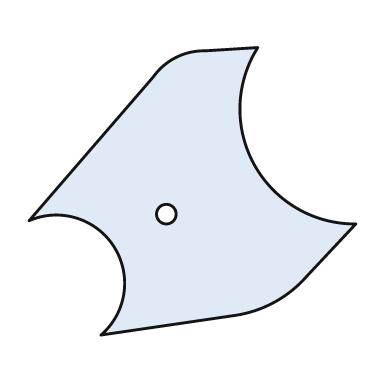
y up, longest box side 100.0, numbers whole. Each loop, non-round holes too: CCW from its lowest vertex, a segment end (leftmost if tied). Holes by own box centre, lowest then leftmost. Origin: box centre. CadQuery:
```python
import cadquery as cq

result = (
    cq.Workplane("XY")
    .moveTo(-28.0, -44.0)
    .lineTo(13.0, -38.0)
    .threePointArc((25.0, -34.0), (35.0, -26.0))
    .lineTo(50.0, -10.0)
    .threePointArc((19.0, 8.0), (20.0, 44.0))
    .lineTo(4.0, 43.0)
    .threePointArc((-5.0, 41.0), (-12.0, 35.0))
    .lineTo(-50.0, -9.0)
    .threePointArc((-24.0, -17.0), (-28.0, -44.0))
    .close()
    .moveTo(-8.0, -7.0)
    .circle(3.0)
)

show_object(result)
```